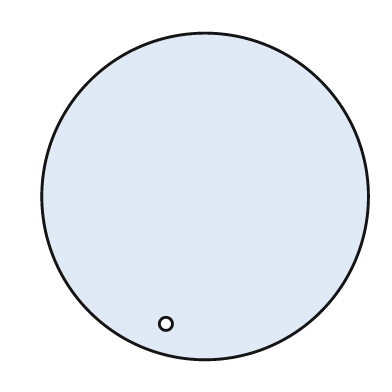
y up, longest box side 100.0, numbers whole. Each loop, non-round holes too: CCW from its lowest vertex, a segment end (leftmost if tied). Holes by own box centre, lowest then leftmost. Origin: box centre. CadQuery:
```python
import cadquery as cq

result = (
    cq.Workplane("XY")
    .moveTo(0.0, 0.0)
    .circle(50.0)
    .moveTo(-12.0, -39.0)
    .circle(2.0)
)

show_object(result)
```